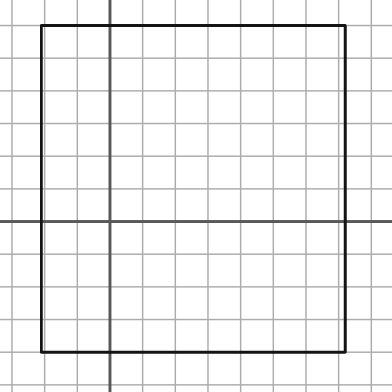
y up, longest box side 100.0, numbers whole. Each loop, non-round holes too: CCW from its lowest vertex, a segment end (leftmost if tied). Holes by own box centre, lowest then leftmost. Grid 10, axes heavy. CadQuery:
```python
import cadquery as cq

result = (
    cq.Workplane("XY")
    .moveTo(-21.0, -40.0)
    .lineTo(72.0, -40.0)
    .lineTo(72.0, 60.0)
    .lineTo(-21.0, 60.0)
    .close()
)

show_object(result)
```